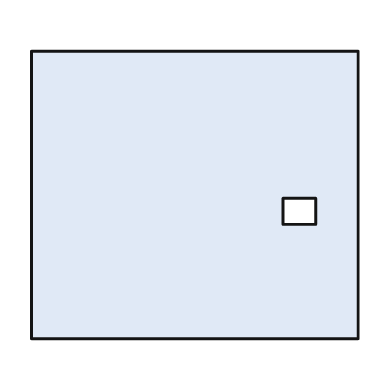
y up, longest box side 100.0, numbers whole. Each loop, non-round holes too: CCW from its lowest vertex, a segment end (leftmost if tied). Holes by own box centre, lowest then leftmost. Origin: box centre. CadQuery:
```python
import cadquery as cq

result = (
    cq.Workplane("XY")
    .moveTo(-50.0, -44.0)
    .lineTo(50.0, -44.0)
    .lineTo(50.0, 44.0)
    .lineTo(-50.0, 44.0)
    .close()
    .moveTo(27.0, -9.0)
    .lineTo(37.0, -9.0)
    .lineTo(37.0, -1.0)
    .lineTo(27.0, -1.0)
    .close()
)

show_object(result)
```